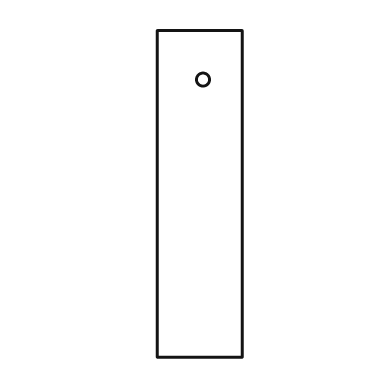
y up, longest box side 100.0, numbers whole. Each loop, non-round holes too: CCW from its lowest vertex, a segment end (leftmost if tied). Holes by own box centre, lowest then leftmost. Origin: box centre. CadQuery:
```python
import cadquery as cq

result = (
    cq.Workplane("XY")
    .moveTo(-13.0, -50.0)
    .lineTo(13.0, -50.0)
    .lineTo(13.0, 50.0)
    .lineTo(-13.0, 50.0)
    .close()
    .moveTo(1.0, 35.0)
    .circle(2.0)
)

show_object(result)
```